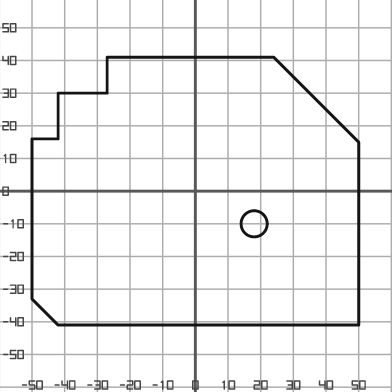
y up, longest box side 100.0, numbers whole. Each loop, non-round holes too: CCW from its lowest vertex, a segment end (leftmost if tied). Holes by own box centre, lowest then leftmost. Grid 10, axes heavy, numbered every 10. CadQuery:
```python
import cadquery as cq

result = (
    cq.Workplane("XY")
    .moveTo(-42.0, -41.0)
    .lineTo(50.0, -41.0)
    .lineTo(50.0, 15.0)
    .lineTo(24.0, 41.0)
    .lineTo(-27.0, 41.0)
    .lineTo(-27.0, 30.0)
    .lineTo(-42.0, 30.0)
    .lineTo(-42.0, 16.0)
    .lineTo(-50.0, 16.0)
    .lineTo(-50.0, -33.0)
    .close()
    .moveTo(18.0, -10.0)
    .circle(4.0)
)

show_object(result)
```